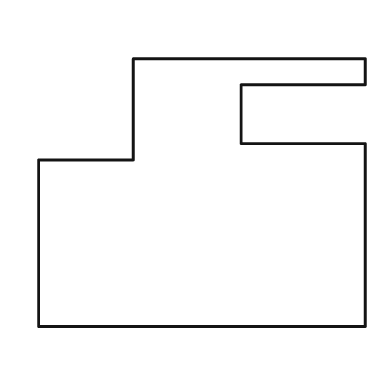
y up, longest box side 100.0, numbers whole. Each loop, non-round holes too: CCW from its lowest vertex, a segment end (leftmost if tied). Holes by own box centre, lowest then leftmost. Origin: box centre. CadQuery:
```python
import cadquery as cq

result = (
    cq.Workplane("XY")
    .moveTo(-50.0, -41.0)
    .lineTo(50.0, -41.0)
    .lineTo(50.0, 15.0)
    .lineTo(12.0, 15.0)
    .lineTo(12.0, 33.0)
    .lineTo(50.0, 33.0)
    .lineTo(50.0, 41.0)
    .lineTo(-21.0, 41.0)
    .lineTo(-21.0, 10.0)
    .lineTo(-50.0, 10.0)
    .close()
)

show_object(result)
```